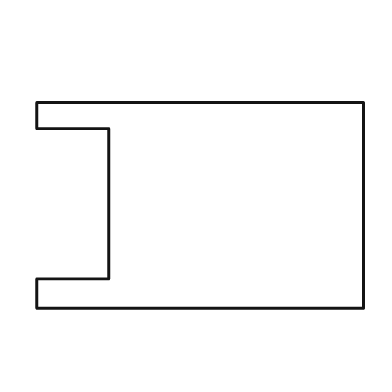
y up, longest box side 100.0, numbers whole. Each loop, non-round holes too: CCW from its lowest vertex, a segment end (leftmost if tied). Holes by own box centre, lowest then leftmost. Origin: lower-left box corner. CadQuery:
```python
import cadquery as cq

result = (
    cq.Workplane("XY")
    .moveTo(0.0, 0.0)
    .lineTo(100.0, 0.0)
    .lineTo(100.0, 63.0)
    .lineTo(0.0, 63.0)
    .lineTo(0.0, 55.0)
    .lineTo(22.0, 55.0)
    .lineTo(22.0, 9.0)
    .lineTo(0.0, 9.0)
    .close()
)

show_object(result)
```